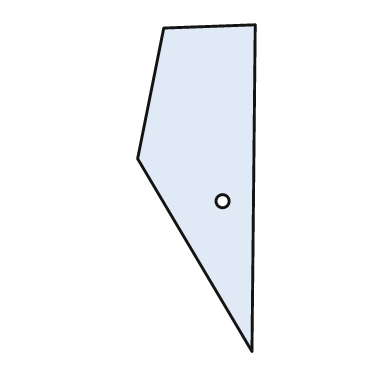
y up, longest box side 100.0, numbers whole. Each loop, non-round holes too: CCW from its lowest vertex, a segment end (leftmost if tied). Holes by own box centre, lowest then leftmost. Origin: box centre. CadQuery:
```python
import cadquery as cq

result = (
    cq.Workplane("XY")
    .moveTo(17.0, -50.0)
    .lineTo(18.0, 50.0)
    .lineTo(-10.0, 49.0)
    .lineTo(-18.0, 9.0)
    .close()
    .moveTo(8.0, -4.0)
    .circle(2.0)
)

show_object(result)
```